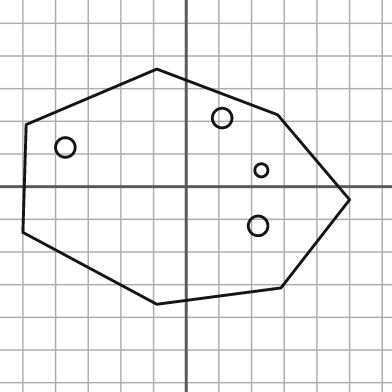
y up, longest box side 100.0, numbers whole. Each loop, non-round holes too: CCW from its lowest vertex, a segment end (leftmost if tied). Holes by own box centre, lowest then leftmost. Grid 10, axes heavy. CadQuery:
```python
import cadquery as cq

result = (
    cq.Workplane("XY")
    .moveTo(-9.0, -36.0)
    .lineTo(29.0, -31.0)
    .lineTo(50.0, -4.0)
    .lineTo(28.0, 22.0)
    .lineTo(-9.0, 36.0)
    .lineTo(-49.0, 19.0)
    .lineTo(-50.0, -14.0)
    .close()
    .moveTo(22.0, -12.0)
    .circle(3.0)
    .moveTo(23.0, 5.0)
    .circle(2.0)
    .moveTo(-37.0, 12.0)
    .circle(3.0)
    .moveTo(11.0, 21.0)
    .circle(3.0)
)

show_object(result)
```